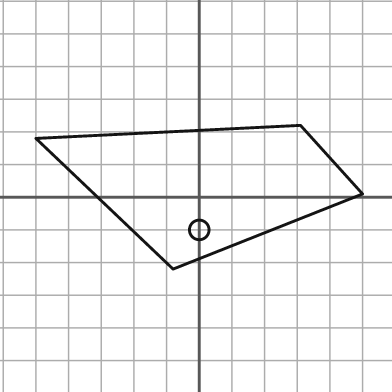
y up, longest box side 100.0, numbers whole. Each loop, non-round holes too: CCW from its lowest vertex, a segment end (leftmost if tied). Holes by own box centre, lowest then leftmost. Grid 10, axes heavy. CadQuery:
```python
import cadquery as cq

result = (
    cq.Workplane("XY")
    .moveTo(-8.0, -22.0)
    .lineTo(50.0, 1.0)
    .lineTo(31.0, 22.0)
    .lineTo(-50.0, 18.0)
    .close()
    .moveTo(0.0, -10.0)
    .circle(3.0)
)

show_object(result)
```